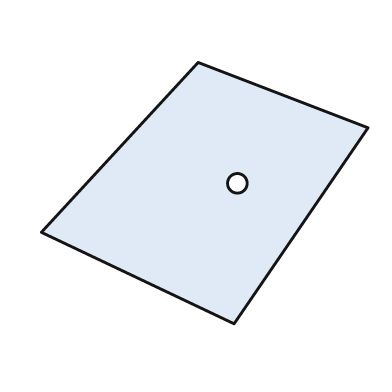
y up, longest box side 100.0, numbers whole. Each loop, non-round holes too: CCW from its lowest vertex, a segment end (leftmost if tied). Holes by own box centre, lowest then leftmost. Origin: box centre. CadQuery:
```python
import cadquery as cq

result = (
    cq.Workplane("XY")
    .moveTo(9.0, -40.0)
    .lineTo(50.0, 20.0)
    .lineTo(-2.0, 40.0)
    .lineTo(-50.0, -12.0)
    .close()
    .moveTo(10.0, 3.0)
    .circle(3.0)
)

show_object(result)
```